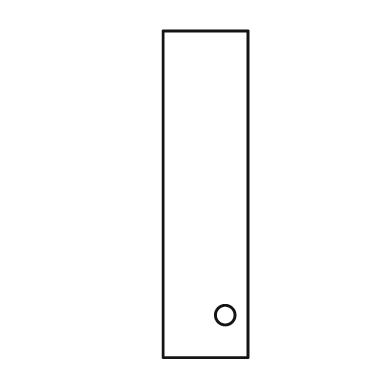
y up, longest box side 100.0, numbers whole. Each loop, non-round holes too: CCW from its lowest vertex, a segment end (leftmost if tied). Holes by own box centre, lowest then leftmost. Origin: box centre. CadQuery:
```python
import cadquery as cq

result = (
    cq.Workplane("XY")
    .moveTo(-13.0, -50.0)
    .lineTo(13.0, -50.0)
    .lineTo(13.0, 50.0)
    .lineTo(-13.0, 50.0)
    .close()
    .moveTo(6.0, -37.0)
    .circle(3.0)
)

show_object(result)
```